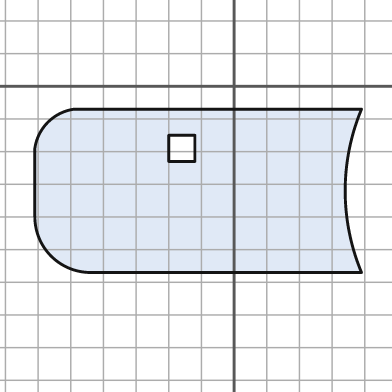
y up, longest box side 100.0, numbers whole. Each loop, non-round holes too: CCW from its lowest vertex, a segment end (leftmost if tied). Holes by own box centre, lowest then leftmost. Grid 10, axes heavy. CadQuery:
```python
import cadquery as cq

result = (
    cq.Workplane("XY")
    .moveTo(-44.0, -57.0)
    .lineTo(39.0, -57.0)
    .threePointArc((34.0, -32.0), (39.0, -7.0))
    .lineTo(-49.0, -7.0)
    .threePointArc((-57.0, -11.0), (-61.0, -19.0))
    .lineTo(-61.0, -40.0)
    .threePointArc((-56.0, -52.0), (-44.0, -57.0))
    .close()
    .moveTo(-20.0, -23.0)
    .lineTo(-12.0, -23.0)
    .lineTo(-12.0, -15.0)
    .lineTo(-20.0, -15.0)
    .close()
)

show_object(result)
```